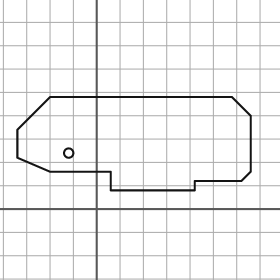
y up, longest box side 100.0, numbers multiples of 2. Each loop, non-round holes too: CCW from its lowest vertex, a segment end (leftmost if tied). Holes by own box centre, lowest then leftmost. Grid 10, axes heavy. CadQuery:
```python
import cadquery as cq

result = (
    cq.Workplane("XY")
    .moveTo(6.0, 8.0)
    .lineTo(42.0, 8.0)
    .lineTo(42.0, 12.0)
    .lineTo(62.0, 12.0)
    .lineTo(66.0, 16.0)
    .lineTo(66.0, 40.0)
    .lineTo(58.0, 48.0)
    .lineTo(-20.0, 48.0)
    .lineTo(-34.0, 34.0)
    .lineTo(-34.0, 22.0)
    .lineTo(-20.0, 16.0)
    .lineTo(6.0, 16.0)
    .close()
    .moveTo(-12.0, 24.0)
    .circle(2.0)
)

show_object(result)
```